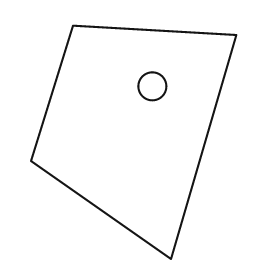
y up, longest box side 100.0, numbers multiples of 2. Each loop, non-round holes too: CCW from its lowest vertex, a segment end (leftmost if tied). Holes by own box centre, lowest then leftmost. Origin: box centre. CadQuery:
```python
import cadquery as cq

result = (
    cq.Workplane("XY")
    .moveTo(16.0, -50.0)
    .lineTo(44.0, 46.0)
    .lineTo(-26.0, 50.0)
    .lineTo(-44.0, -8.0)
    .close()
    .moveTo(8.0, 24.0)
    .circle(6.0)
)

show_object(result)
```